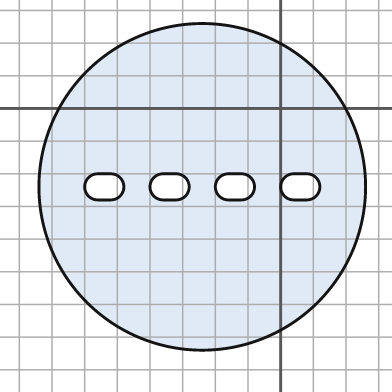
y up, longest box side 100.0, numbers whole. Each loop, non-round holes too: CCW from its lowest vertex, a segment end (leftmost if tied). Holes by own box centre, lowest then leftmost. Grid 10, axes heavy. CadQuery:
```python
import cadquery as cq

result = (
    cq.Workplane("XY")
    .moveTo(-24.0, -24.0)
    .circle(50.0)
    .moveTo(-56.0, -28.0)
    .lineTo(-52.0, -28.0)
    .threePointArc((-48.0, -24.0), (-52.0, -20.0))
    .lineTo(-56.0, -20.0)
    .threePointArc((-60.0, -24.0), (-56.0, -28.0))
    .close()
    .moveTo(-36.0, -28.0)
    .lineTo(-32.0, -28.0)
    .threePointArc((-28.0, -24.0), (-32.0, -20.0))
    .lineTo(-36.0, -20.0)
    .threePointArc((-40.0, -24.0), (-36.0, -28.0))
    .close()
    .moveTo(-16.0, -28.0)
    .lineTo(-12.0, -28.0)
    .threePointArc((-8.0, -24.0), (-12.0, -20.0))
    .lineTo(-16.0, -20.0)
    .threePointArc((-20.0, -24.0), (-16.0, -28.0))
    .close()
    .moveTo(4.0, -28.0)
    .lineTo(8.0, -28.0)
    .threePointArc((12.0, -24.0), (8.0, -20.0))
    .lineTo(4.0, -20.0)
    .threePointArc((0.0, -24.0), (4.0, -28.0))
    .close()
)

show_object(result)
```